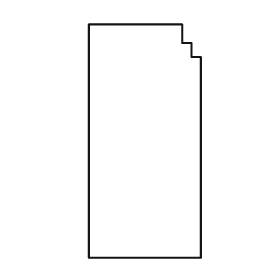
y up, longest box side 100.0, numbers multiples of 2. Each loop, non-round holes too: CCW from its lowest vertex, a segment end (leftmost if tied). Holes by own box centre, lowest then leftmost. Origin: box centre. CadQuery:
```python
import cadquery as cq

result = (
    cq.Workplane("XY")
    .moveTo(-24.0, -50.0)
    .lineTo(24.0, -50.0)
    .lineTo(24.0, 36.0)
    .lineTo(20.0, 36.0)
    .lineTo(20.0, 42.0)
    .lineTo(16.0, 42.0)
    .lineTo(16.0, 50.0)
    .lineTo(-24.0, 50.0)
    .close()
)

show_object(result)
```